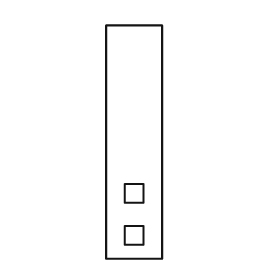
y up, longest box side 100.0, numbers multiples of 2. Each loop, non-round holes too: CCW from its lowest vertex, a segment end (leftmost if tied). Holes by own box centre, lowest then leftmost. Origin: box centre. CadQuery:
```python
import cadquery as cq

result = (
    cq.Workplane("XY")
    .moveTo(-12.0, -50.0)
    .lineTo(12.0, -50.0)
    .lineTo(12.0, 50.0)
    .lineTo(-12.0, 50.0)
    .close()
    .moveTo(-4.0, -44.0)
    .lineTo(4.0, -44.0)
    .lineTo(4.0, -36.0)
    .lineTo(-4.0, -36.0)
    .close()
    .moveTo(-4.0, -26.0)
    .lineTo(4.0, -26.0)
    .lineTo(4.0, -18.0)
    .lineTo(-4.0, -18.0)
    .close()
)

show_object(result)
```